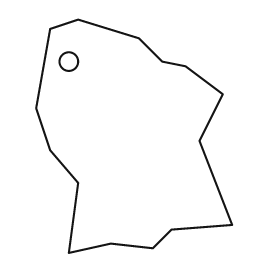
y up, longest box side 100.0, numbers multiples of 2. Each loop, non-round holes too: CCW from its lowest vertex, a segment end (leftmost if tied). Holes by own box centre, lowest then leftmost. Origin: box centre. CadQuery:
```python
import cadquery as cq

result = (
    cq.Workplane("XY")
    .moveTo(-28.0, -50.0)
    .lineTo(-10.0, -46.0)
    .lineTo(8.0, -48.0)
    .lineTo(16.0, -40.0)
    .lineTo(42.0, -38.0)
    .lineTo(28.0, -2.0)
    .lineTo(38.0, 18.0)
    .lineTo(22.0, 30.0)
    .lineTo(12.0, 32.0)
    .lineTo(2.0, 42.0)
    .lineTo(-24.0, 50.0)
    .lineTo(-36.0, 46.0)
    .lineTo(-42.0, 12.0)
    .lineTo(-36.0, -6.0)
    .lineTo(-24.0, -20.0)
    .close()
    .moveTo(-28.0, 32.0)
    .circle(4.0)
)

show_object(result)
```